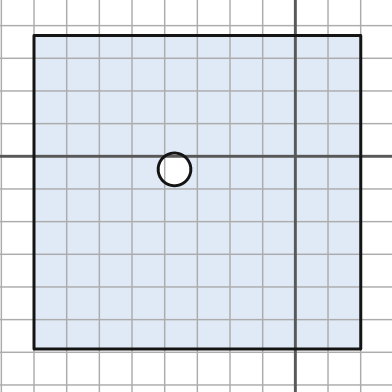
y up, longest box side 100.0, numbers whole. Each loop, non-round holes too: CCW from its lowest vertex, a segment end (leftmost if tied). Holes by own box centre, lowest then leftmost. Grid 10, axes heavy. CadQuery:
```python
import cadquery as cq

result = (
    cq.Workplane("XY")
    .moveTo(-80.0, -59.0)
    .lineTo(20.0, -59.0)
    .lineTo(20.0, 37.0)
    .lineTo(-80.0, 37.0)
    .close()
    .moveTo(-37.0, -4.0)
    .circle(5.0)
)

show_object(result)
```